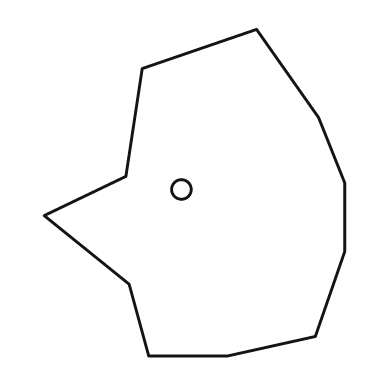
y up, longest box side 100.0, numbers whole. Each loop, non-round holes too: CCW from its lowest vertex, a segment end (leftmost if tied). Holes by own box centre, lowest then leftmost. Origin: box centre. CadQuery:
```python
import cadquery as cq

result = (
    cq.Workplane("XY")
    .moveTo(-14.0, -50.0)
    .lineTo(10.0, -50.0)
    .lineTo(37.0, -44.0)
    .lineTo(46.0, -18.0)
    .lineTo(46.0, 3.0)
    .lineTo(38.0, 23.0)
    .lineTo(19.0, 50.0)
    .lineTo(-16.0, 38.0)
    .lineTo(-21.0, 5.0)
    .lineTo(-46.0, -7.0)
    .lineTo(-20.0, -28.0)
    .close()
    .moveTo(-4.0, 1.0)
    .circle(3.0)
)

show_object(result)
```